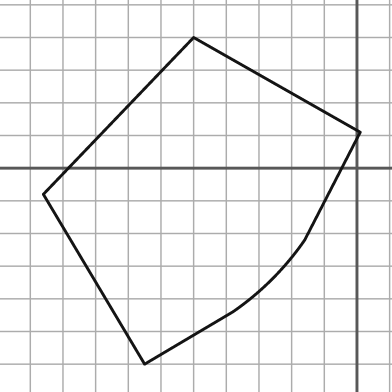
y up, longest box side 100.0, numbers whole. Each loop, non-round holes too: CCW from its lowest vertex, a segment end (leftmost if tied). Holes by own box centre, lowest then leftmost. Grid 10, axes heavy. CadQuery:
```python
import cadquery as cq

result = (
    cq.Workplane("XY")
    .moveTo(-65.0, -60.0)
    .lineTo(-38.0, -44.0)
    .threePointArc((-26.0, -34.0), (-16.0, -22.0))
    .lineTo(1.0, 11.0)
    .lineTo(-50.0, 40.0)
    .lineTo(-96.0, -8.0)
    .close()
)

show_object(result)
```